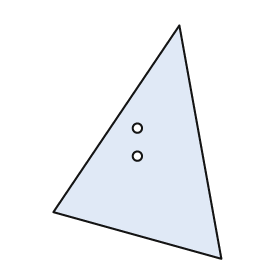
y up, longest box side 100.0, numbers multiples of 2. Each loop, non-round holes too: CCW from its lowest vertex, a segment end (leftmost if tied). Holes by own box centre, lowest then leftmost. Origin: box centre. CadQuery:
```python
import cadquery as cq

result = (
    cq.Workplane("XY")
    .moveTo(36.0, -50.0)
    .lineTo(18.0, 50.0)
    .lineTo(-36.0, -30.0)
    .close()
    .moveTo(0.0, -6.0)
    .circle(2.0)
    .moveTo(0.0, 6.0)
    .circle(2.0)
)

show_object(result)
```